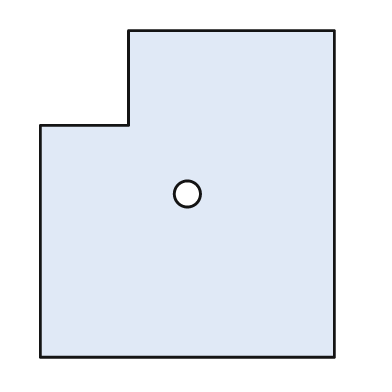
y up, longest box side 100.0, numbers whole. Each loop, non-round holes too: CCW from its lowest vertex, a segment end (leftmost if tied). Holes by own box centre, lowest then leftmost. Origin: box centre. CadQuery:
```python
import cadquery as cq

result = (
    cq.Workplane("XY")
    .moveTo(-45.0, -50.0)
    .lineTo(45.0, -50.0)
    .lineTo(45.0, 50.0)
    .lineTo(-18.0, 50.0)
    .lineTo(-18.0, 21.0)
    .lineTo(-45.0, 21.0)
    .close()
    .moveTo(0.0, 0.0)
    .circle(4.0)
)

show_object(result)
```